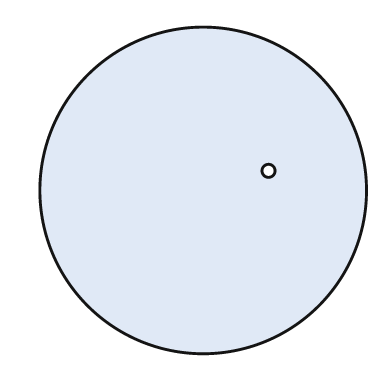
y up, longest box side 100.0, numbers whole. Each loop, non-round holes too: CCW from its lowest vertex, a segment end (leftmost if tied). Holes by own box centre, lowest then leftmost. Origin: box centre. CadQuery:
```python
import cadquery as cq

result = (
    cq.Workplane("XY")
    .moveTo(0.0, 0.0)
    .circle(50.0)
    .moveTo(20.0, 6.0)
    .circle(2.0)
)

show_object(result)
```